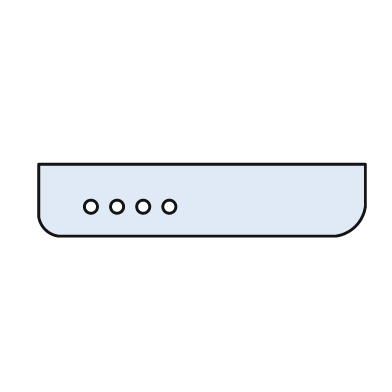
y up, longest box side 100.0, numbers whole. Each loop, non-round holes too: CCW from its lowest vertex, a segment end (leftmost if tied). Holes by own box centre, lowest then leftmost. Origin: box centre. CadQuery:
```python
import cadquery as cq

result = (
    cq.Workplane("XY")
    .moveTo(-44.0, -11.0)
    .lineTo(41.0, -11.0)
    .threePointArc((47.0, -8.0), (50.0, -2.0))
    .lineTo(50.0, 11.0)
    .lineTo(-50.0, 11.0)
    .lineTo(-50.0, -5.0)
    .threePointArc((-48.0, -9.0), (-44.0, -11.0))
    .close()
    .moveTo(-34.0, -2.0)
    .circle(2.0)
    .moveTo(-26.0, -2.0)
    .circle(2.0)
    .moveTo(-18.0, -2.0)
    .circle(2.0)
    .moveTo(-10.0, -2.0)
    .circle(2.0)
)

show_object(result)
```